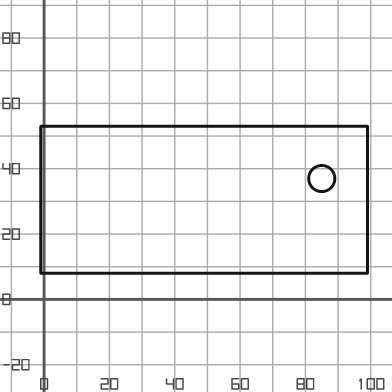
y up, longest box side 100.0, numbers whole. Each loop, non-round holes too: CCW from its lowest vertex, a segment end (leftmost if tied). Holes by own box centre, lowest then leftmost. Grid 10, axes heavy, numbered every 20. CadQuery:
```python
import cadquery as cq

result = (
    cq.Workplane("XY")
    .moveTo(-1.0, 8.0)
    .lineTo(99.0, 8.0)
    .lineTo(99.0, 53.0)
    .lineTo(-1.0, 53.0)
    .close()
    .moveTo(85.0, 37.0)
    .circle(4.0)
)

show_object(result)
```